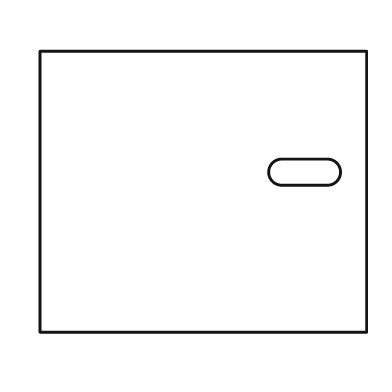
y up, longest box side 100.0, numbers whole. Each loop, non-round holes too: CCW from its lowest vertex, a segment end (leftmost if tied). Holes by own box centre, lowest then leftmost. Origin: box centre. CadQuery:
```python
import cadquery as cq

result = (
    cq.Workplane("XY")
    .moveTo(-50.0, -43.0)
    .lineTo(50.0, -43.0)
    .lineTo(50.0, 43.0)
    .lineTo(-50.0, 43.0)
    .close()
    .moveTo(24.0, 2.0)
    .lineTo(38.0, 2.0)
    .threePointArc((42.0, 6.0), (38.0, 10.0))
    .lineTo(24.0, 10.0)
    .threePointArc((20.0, 6.0), (24.0, 2.0))
    .close()
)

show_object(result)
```